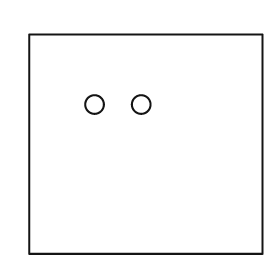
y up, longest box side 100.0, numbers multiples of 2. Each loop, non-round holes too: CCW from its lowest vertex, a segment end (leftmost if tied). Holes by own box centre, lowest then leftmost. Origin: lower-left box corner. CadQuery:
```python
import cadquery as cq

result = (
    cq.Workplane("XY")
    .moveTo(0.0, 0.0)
    .lineTo(100.0, 0.0)
    .lineTo(100.0, 94.0)
    .lineTo(0.0, 94.0)
    .close()
    .moveTo(28.0, 64.0)
    .circle(4.0)
    .moveTo(48.0, 64.0)
    .circle(4.0)
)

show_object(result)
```